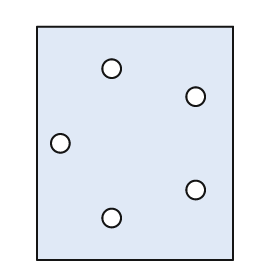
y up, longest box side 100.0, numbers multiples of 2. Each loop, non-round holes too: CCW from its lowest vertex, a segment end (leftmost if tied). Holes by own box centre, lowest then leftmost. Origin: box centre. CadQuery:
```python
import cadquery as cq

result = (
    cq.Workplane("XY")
    .moveTo(-42.0, -50.0)
    .lineTo(42.0, -50.0)
    .lineTo(42.0, 50.0)
    .lineTo(-42.0, 50.0)
    .close()
    .moveTo(-10.0, -32.0)
    .circle(4.0)
    .moveTo(26.0, -20.0)
    .circle(4.0)
    .moveTo(-32.0, 0.0)
    .circle(4.0)
    .moveTo(26.0, 20.0)
    .circle(4.0)
    .moveTo(-10.0, 32.0)
    .circle(4.0)
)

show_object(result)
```